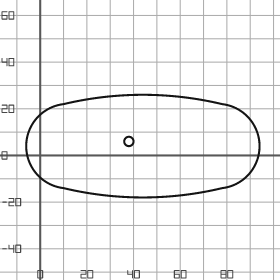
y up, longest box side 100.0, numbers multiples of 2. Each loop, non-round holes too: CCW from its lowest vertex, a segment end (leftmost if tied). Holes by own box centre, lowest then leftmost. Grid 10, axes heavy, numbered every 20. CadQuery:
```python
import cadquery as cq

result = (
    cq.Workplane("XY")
    .moveTo(10.0, -14.0)
    .threePointArc((44.0, -18.0), (78.0, -14.0))
    .threePointArc((94.0, 4.0), (78.0, 22.0))
    .threePointArc((44.0, 26.0), (10.0, 22.0))
    .threePointArc((-6.0, 4.0), (10.0, -14.0))
    .close()
    .moveTo(38.0, 6.0)
    .circle(2.0)
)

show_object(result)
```